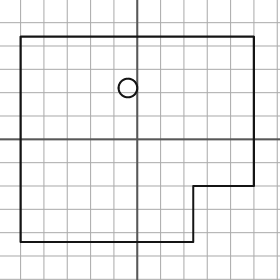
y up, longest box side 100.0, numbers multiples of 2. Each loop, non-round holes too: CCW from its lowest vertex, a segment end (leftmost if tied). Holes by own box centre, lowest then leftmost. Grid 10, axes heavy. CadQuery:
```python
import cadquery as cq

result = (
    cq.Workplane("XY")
    .moveTo(-50.0, -44.0)
    .lineTo(24.0, -44.0)
    .lineTo(24.0, -20.0)
    .lineTo(50.0, -20.0)
    .lineTo(50.0, 44.0)
    .lineTo(-50.0, 44.0)
    .close()
    .moveTo(-4.0, 22.0)
    .circle(4.0)
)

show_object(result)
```